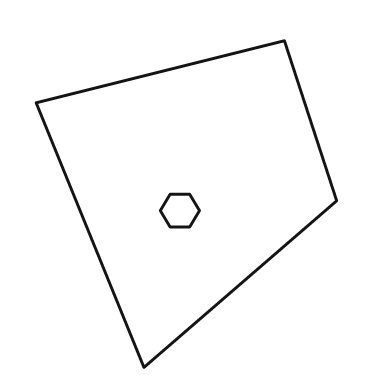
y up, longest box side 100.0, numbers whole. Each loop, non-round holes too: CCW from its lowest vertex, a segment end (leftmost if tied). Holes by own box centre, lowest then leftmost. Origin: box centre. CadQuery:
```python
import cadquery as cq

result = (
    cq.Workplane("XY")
    .moveTo(-13.0, -50.0)
    .lineTo(46.0, 1.0)
    .lineTo(30.0, 50.0)
    .lineTo(-46.0, 31.0)
    .close()
    .moveTo(-5.0, -7.0)
    .lineTo(1.0, -7.0)
    .lineTo(4.0, -2.0)
    .lineTo(1.0, 3.0)
    .lineTo(-5.0, 3.0)
    .lineTo(-8.0, -2.0)
    .close()
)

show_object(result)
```